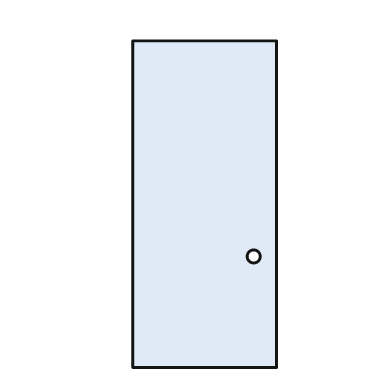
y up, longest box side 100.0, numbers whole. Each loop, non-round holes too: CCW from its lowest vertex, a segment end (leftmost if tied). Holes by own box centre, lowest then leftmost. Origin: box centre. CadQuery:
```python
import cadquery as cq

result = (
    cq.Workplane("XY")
    .moveTo(-22.0, -50.0)
    .lineTo(22.0, -50.0)
    .lineTo(22.0, 50.0)
    .lineTo(-22.0, 50.0)
    .close()
    .moveTo(15.0, -16.0)
    .circle(2.0)
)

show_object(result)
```